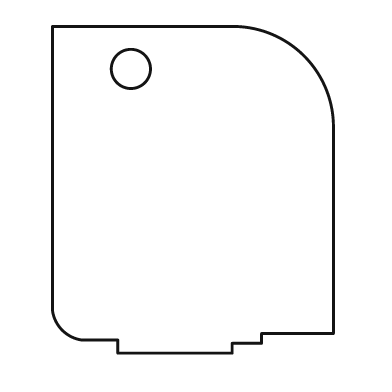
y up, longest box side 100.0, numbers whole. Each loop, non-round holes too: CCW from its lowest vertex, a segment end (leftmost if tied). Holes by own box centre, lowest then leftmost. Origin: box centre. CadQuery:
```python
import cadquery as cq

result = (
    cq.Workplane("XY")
    .moveTo(-23.0, -50.0)
    .lineTo(12.0, -50.0)
    .lineTo(12.0, -47.0)
    .lineTo(21.0, -47.0)
    .lineTo(21.0, -44.0)
    .lineTo(43.0, -44.0)
    .lineTo(43.0, 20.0)
    .threePointArc((34.0, 41.0), (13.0, 50.0))
    .lineTo(-43.0, 50.0)
    .lineTo(-43.0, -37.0)
    .threePointArc((-40.0, -43.0), (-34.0, -46.0))
    .lineTo(-23.0, -46.0)
    .close()
    .moveTo(-19.0, 37.0)
    .circle(6.0)
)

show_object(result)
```